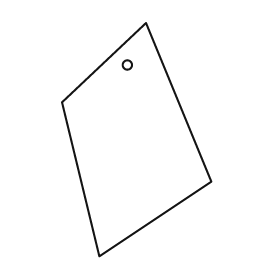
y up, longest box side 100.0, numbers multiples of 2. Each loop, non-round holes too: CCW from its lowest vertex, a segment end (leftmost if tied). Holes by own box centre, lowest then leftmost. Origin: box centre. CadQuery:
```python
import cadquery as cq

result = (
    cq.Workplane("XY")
    .moveTo(-16.0, -50.0)
    .lineTo(32.0, -18.0)
    .lineTo(4.0, 50.0)
    .lineTo(-32.0, 16.0)
    .close()
    .moveTo(-4.0, 32.0)
    .circle(2.0)
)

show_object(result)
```